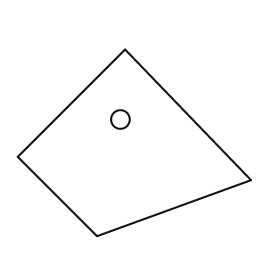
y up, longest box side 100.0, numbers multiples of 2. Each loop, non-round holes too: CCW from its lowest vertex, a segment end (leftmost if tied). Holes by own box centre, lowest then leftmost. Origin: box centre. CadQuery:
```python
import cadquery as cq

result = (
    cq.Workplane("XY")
    .moveTo(-16.0, -40.0)
    .lineTo(50.0, -16.0)
    .lineTo(-4.0, 40.0)
    .lineTo(-50.0, -6.0)
    .close()
    .moveTo(-6.0, 10.0)
    .circle(4.0)
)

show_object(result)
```